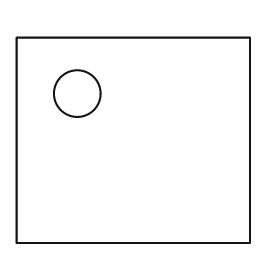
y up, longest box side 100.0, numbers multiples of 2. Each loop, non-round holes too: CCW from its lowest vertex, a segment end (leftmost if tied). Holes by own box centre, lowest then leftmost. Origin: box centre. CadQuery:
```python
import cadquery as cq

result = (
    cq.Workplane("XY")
    .moveTo(-50.0, -44.0)
    .lineTo(50.0, -44.0)
    .lineTo(50.0, 44.0)
    .lineTo(-50.0, 44.0)
    .close()
    .moveTo(-24.0, 20.0)
    .circle(10.0)
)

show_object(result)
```